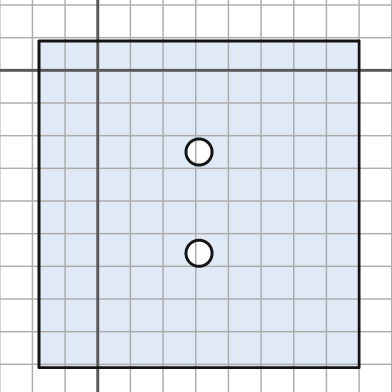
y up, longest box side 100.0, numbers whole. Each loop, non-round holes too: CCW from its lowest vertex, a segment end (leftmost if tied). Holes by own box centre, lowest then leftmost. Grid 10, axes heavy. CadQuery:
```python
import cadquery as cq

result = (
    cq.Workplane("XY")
    .moveTo(-18.0, -91.0)
    .lineTo(80.0, -91.0)
    .lineTo(80.0, 9.0)
    .lineTo(-18.0, 9.0)
    .close()
    .moveTo(31.0, -56.0)
    .circle(4.0)
    .moveTo(31.0, -25.0)
    .circle(4.0)
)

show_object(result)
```